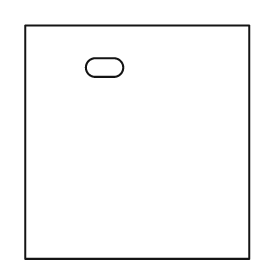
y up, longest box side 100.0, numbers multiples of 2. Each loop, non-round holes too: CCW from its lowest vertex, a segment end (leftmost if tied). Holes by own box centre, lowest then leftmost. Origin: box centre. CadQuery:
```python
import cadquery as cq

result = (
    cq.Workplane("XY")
    .moveTo(-48.0, -50.0)
    .lineTo(48.0, -50.0)
    .lineTo(48.0, 50.0)
    .lineTo(-48.0, 50.0)
    .close()
    .moveTo(-18.0, 28.0)
    .lineTo(-10.0, 28.0)
    .threePointArc((-6.0, 32.0), (-10.0, 36.0))
    .lineTo(-18.0, 36.0)
    .threePointArc((-22.0, 32.0), (-18.0, 28.0))
    .close()
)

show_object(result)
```